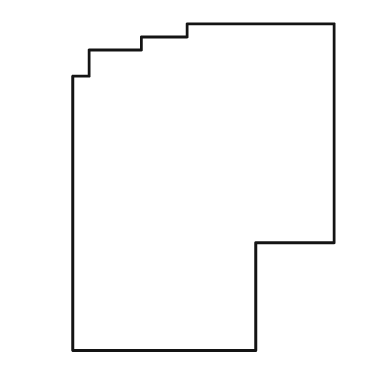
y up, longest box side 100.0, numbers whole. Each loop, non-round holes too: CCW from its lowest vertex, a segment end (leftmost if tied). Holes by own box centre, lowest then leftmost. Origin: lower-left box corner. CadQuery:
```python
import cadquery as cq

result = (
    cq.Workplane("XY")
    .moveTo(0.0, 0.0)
    .lineTo(56.0, 0.0)
    .lineTo(56.0, 33.0)
    .lineTo(80.0, 33.0)
    .lineTo(80.0, 100.0)
    .lineTo(35.0, 100.0)
    .lineTo(35.0, 96.0)
    .lineTo(21.0, 96.0)
    .lineTo(21.0, 92.0)
    .lineTo(5.0, 92.0)
    .lineTo(5.0, 84.0)
    .lineTo(0.0, 84.0)
    .close()
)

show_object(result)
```